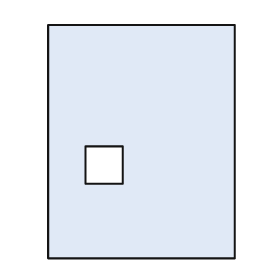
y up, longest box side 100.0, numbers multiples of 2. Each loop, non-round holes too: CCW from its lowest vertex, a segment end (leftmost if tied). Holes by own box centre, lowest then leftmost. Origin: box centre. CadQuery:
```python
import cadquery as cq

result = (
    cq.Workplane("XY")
    .moveTo(-40.0, -50.0)
    .lineTo(40.0, -50.0)
    .lineTo(40.0, 50.0)
    .lineTo(-40.0, 50.0)
    .close()
    .moveTo(-24.0, -18.0)
    .lineTo(-8.0, -18.0)
    .lineTo(-8.0, -2.0)
    .lineTo(-24.0, -2.0)
    .close()
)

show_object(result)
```